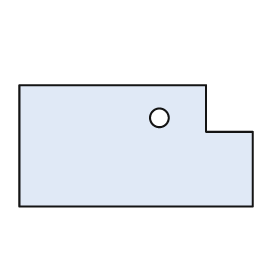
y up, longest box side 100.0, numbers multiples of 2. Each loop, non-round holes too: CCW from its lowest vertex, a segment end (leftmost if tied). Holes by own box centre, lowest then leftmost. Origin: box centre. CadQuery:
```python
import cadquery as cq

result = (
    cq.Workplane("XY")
    .moveTo(-50.0, -26.0)
    .lineTo(50.0, -26.0)
    .lineTo(50.0, 6.0)
    .lineTo(30.0, 6.0)
    .lineTo(30.0, 26.0)
    .lineTo(-50.0, 26.0)
    .close()
    .moveTo(10.0, 12.0)
    .circle(4.0)
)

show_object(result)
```